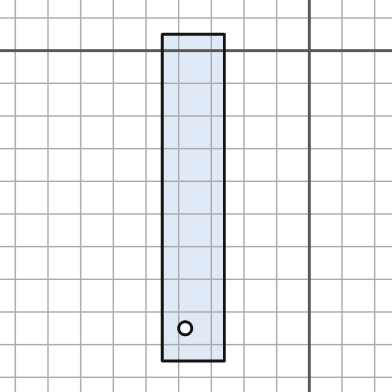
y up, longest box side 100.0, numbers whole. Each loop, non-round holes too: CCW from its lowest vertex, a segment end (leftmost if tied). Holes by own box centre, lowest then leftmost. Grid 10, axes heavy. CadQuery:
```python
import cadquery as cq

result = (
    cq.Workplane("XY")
    .moveTo(-45.0, -95.0)
    .lineTo(-26.0, -95.0)
    .lineTo(-26.0, 5.0)
    .lineTo(-45.0, 5.0)
    .close()
    .moveTo(-38.0, -85.0)
    .circle(2.0)
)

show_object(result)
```